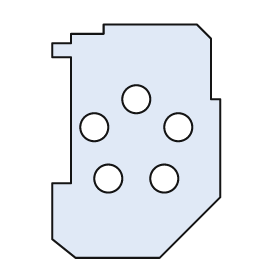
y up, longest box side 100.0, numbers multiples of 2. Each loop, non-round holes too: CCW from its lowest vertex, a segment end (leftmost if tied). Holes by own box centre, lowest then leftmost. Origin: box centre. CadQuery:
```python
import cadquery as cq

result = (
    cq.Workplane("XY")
    .moveTo(-26.0, -50.0)
    .lineTo(10.0, -50.0)
    .lineTo(36.0, -24.0)
    .lineTo(36.0, 18.0)
    .lineTo(32.0, 18.0)
    .lineTo(32.0, 44.0)
    .lineTo(26.0, 50.0)
    .lineTo(-14.0, 50.0)
    .lineTo(-14.0, 46.0)
    .lineTo(-28.0, 46.0)
    .lineTo(-28.0, 42.0)
    .lineTo(-36.0, 42.0)
    .lineTo(-36.0, 36.0)
    .lineTo(-28.0, 36.0)
    .lineTo(-28.0, -18.0)
    .lineTo(-36.0, -18.0)
    .lineTo(-36.0, -42.0)
    .close()
    .moveTo(-12.0, -16.0)
    .circle(6.0)
    .moveTo(12.0, -16.0)
    .circle(6.0)
    .moveTo(-18.0, 6.0)
    .circle(6.0)
    .moveTo(18.0, 6.0)
    .circle(6.0)
    .moveTo(0.0, 18.0)
    .circle(6.0)
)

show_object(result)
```